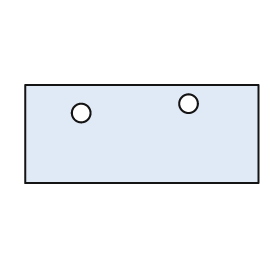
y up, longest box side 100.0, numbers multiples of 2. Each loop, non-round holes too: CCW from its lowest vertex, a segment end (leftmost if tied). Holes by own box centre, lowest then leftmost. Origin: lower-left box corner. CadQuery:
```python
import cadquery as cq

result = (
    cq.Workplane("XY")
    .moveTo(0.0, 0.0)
    .lineTo(100.0, 0.0)
    .lineTo(100.0, 42.0)
    .lineTo(0.0, 42.0)
    .close()
    .moveTo(24.0, 30.0)
    .circle(4.0)
    .moveTo(70.0, 34.0)
    .circle(4.0)
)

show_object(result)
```